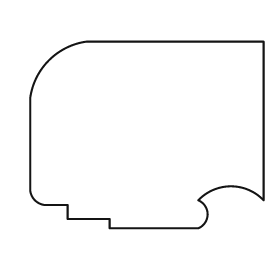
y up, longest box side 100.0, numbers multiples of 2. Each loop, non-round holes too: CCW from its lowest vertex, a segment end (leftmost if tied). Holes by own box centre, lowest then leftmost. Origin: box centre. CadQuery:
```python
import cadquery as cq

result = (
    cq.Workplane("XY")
    .moveTo(-16.0, -40.0)
    .lineTo(22.0, -40.0)
    .threePointArc((26.0, -34.0), (22.0, -28.0))
    .threePointArc((36.0, -22.0), (50.0, -28.0))
    .lineTo(50.0, 40.0)
    .lineTo(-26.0, 40.0)
    .threePointArc((-42.0, 32.0), (-50.0, 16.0))
    .lineTo(-50.0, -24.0)
    .threePointArc((-48.0, -28.0), (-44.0, -30.0))
    .lineTo(-34.0, -30.0)
    .lineTo(-34.0, -36.0)
    .lineTo(-16.0, -36.0)
    .close()
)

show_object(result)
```